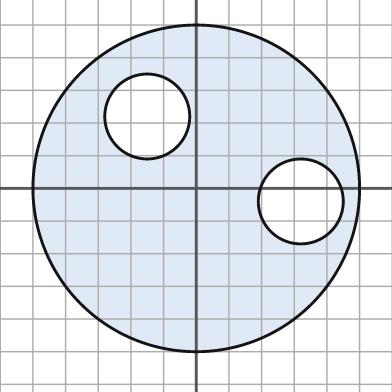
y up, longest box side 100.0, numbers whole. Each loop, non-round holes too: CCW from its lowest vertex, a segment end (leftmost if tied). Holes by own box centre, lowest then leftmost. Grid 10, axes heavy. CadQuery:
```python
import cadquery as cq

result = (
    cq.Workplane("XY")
    .moveTo(0.0, 0.0)
    .circle(50.0)
    .moveTo(32.0, -4.0)
    .circle(13.0)
    .moveTo(-15.0, 22.0)
    .circle(13.0)
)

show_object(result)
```